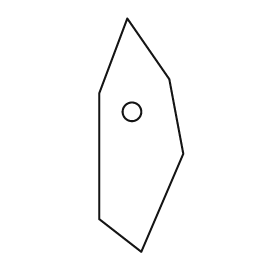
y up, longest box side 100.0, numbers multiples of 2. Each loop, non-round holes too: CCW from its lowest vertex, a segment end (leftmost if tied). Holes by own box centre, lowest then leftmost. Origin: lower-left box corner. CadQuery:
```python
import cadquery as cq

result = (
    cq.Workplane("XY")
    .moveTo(18.0, 0.0)
    .lineTo(36.0, 42.0)
    .lineTo(30.0, 74.0)
    .lineTo(12.0, 100.0)
    .lineTo(0.0, 68.0)
    .lineTo(0.0, 14.0)
    .close()
    .moveTo(14.0, 60.0)
    .circle(4.0)
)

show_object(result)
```